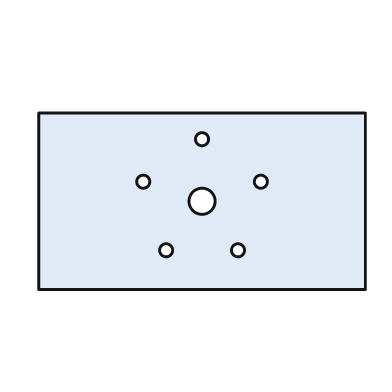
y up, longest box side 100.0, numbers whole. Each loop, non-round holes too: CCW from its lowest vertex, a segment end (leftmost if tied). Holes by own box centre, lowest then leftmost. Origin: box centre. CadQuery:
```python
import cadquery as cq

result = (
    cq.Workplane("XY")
    .moveTo(-50.0, -27.0)
    .lineTo(50.0, -27.0)
    .lineTo(50.0, 27.0)
    .lineTo(-50.0, 27.0)
    .close()
    .moveTo(-11.0, -15.0)
    .circle(2.0)
    .moveTo(11.0, -15.0)
    .circle(2.0)
    .moveTo(0.0, 0.0)
    .circle(4.0)
    .moveTo(-18.0, 6.0)
    .circle(2.0)
    .moveTo(18.0, 6.0)
    .circle(2.0)
    .moveTo(0.0, 19.0)
    .circle(2.0)
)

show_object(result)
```